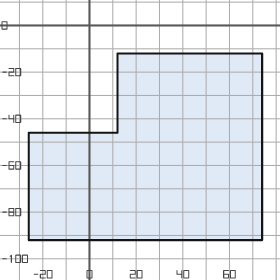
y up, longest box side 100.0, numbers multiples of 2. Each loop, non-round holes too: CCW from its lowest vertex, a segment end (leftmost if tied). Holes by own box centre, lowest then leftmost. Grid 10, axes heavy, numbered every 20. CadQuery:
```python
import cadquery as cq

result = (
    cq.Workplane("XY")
    .moveTo(-26.0, -92.0)
    .lineTo(74.0, -92.0)
    .lineTo(74.0, -12.0)
    .lineTo(12.0, -12.0)
    .lineTo(12.0, -46.0)
    .lineTo(-26.0, -46.0)
    .close()
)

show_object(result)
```